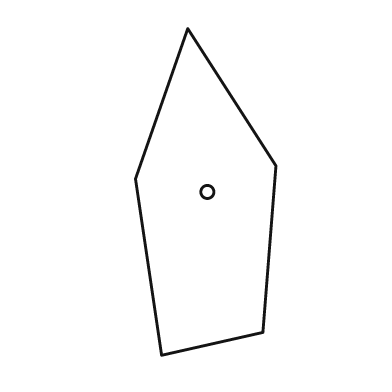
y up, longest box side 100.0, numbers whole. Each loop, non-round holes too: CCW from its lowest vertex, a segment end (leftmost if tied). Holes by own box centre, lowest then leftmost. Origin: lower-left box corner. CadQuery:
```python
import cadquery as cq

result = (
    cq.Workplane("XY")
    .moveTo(8.0, 0.0)
    .lineTo(39.0, 7.0)
    .lineTo(43.0, 58.0)
    .lineTo(16.0, 100.0)
    .lineTo(0.0, 54.0)
    .close()
    .moveTo(22.0, 50.0)
    .circle(2.0)
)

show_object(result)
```